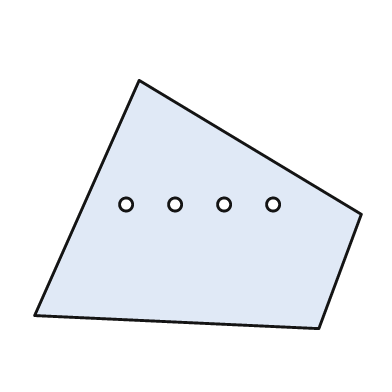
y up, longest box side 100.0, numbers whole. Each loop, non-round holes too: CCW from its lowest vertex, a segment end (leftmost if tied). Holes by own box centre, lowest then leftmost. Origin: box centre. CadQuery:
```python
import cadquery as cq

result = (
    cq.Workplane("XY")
    .moveTo(37.0, -38.0)
    .lineTo(50.0, -3.0)
    .lineTo(-18.0, 38.0)
    .lineTo(-50.0, -34.0)
    .close()
    .moveTo(-22.0, 0.0)
    .circle(2.0)
    .moveTo(-7.0, 0.0)
    .circle(2.0)
    .moveTo(8.0, 0.0)
    .circle(2.0)
    .moveTo(23.0, 0.0)
    .circle(2.0)
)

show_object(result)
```